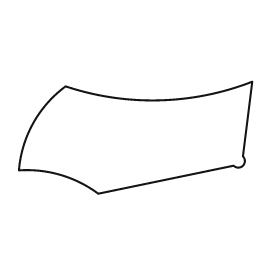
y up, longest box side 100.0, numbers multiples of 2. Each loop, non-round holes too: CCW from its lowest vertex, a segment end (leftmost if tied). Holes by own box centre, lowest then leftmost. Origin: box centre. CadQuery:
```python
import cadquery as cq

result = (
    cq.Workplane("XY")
    .moveTo(-16.0, -24.0)
    .lineTo(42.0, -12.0)
    .threePointArc((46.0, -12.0), (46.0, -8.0))
    .lineTo(50.0, 24.0)
    .threePointArc((10.0, 16.0), (-30.0, 22.0))
    .threePointArc((-44.0, 6.0), (-50.0, -14.0))
    .threePointArc((-32.0, -16.0), (-16.0, -24.0))
    .close()
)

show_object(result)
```